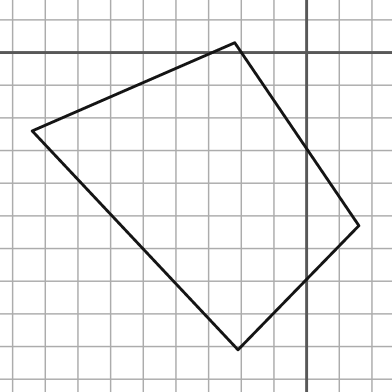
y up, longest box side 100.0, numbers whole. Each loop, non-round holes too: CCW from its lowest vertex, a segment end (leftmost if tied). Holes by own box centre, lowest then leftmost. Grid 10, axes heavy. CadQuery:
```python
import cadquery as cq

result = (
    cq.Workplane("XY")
    .moveTo(-21.0, -91.0)
    .lineTo(16.0, -53.0)
    .lineTo(-22.0, 3.0)
    .lineTo(-84.0, -24.0)
    .close()
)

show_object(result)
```